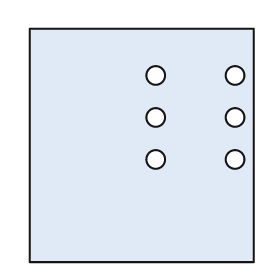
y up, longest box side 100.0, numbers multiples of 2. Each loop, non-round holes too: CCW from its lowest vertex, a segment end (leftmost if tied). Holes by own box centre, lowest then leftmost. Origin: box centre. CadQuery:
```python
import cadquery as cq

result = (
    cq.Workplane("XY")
    .moveTo(-48.0, -50.0)
    .lineTo(48.0, -50.0)
    .lineTo(48.0, 50.0)
    .lineTo(-48.0, 50.0)
    .close()
    .moveTo(6.0, -6.0)
    .circle(4.0)
    .moveTo(40.0, -6.0)
    .circle(4.0)
    .moveTo(6.0, 12.0)
    .circle(4.0)
    .moveTo(40.0, 12.0)
    .circle(4.0)
    .moveTo(6.0, 30.0)
    .circle(4.0)
    .moveTo(40.0, 30.0)
    .circle(4.0)
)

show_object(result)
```